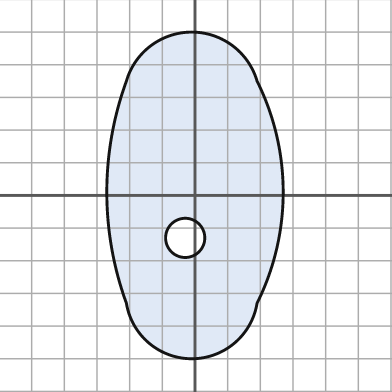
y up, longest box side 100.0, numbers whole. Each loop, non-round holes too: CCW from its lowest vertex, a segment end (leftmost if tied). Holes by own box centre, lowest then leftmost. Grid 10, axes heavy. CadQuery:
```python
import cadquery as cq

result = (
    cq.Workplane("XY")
    .moveTo(-21.0, -33.0)
    .threePointArc((-1.0, -50.0), (19.0, -33.0))
    .threePointArc((27.0, 1.0), (19.0, 35.0))
    .threePointArc((-1.0, 50.0), (-21.0, 35.0))
    .threePointArc((-27.0, 1.0), (-21.0, -33.0))
    .close()
    .moveTo(-3.0, -13.0)
    .circle(6.0)
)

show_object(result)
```